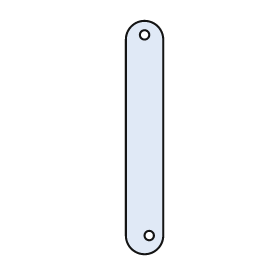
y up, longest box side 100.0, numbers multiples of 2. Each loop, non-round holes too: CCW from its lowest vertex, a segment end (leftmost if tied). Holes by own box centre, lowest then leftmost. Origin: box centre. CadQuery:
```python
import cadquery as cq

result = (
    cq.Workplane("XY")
    .moveTo(-8.0, -42.0)
    .threePointArc((0.0, -50.0), (8.0, -42.0))
    .lineTo(8.0, 42.0)
    .threePointArc((0.0, 50.0), (-8.0, 42.0))
    .close()
    .moveTo(2.0, -42.0)
    .circle(2.0)
    .moveTo(0.0, 44.0)
    .circle(2.0)
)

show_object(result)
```